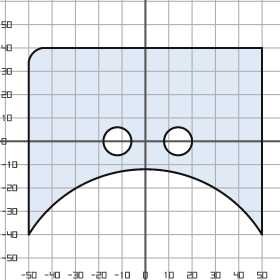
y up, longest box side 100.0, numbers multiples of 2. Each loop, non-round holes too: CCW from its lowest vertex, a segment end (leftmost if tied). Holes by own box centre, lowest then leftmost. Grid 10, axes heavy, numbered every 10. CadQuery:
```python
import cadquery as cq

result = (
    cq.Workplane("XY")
    .moveTo(-50.0, -40.0)
    .threePointArc((0.0, -12.0), (50.0, -40.0))
    .lineTo(50.0, 40.0)
    .lineTo(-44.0, 40.0)
    .threePointArc((-48.0, 38.0), (-50.0, 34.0))
    .close()
    .moveTo(-12.0, 0.0)
    .circle(6.0)
    .moveTo(14.0, 0.0)
    .circle(6.0)
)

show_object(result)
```